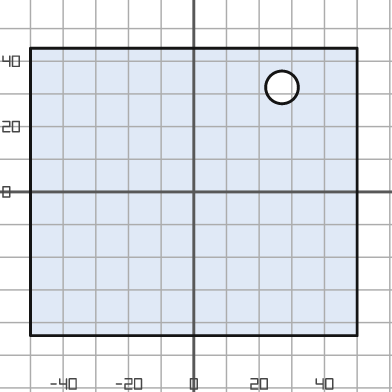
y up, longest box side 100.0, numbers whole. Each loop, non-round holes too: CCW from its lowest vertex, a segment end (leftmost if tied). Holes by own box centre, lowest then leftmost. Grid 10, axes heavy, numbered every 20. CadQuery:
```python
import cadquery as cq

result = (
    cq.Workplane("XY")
    .moveTo(-50.0, -44.0)
    .lineTo(50.0, -44.0)
    .lineTo(50.0, 44.0)
    .lineTo(-50.0, 44.0)
    .close()
    .moveTo(27.0, 32.0)
    .circle(5.0)
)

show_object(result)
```